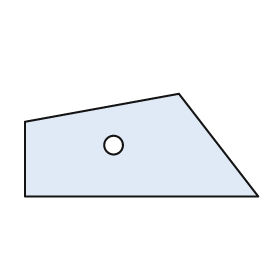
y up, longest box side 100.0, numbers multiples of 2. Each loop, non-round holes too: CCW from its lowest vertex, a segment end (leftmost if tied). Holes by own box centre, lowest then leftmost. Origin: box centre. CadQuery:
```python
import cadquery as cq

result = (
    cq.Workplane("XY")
    .moveTo(-50.0, -22.0)
    .lineTo(50.0, -22.0)
    .lineTo(16.0, 22.0)
    .lineTo(-50.0, 10.0)
    .close()
    .moveTo(-12.0, 0.0)
    .circle(4.0)
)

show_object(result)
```